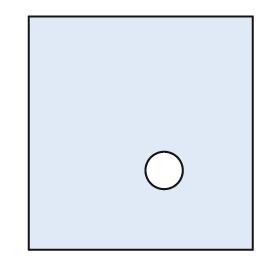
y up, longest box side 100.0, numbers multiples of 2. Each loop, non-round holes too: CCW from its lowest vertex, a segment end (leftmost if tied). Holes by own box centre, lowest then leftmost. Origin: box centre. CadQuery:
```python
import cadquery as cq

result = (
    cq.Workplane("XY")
    .moveTo(-48.0, -50.0)
    .lineTo(48.0, -50.0)
    .lineTo(48.0, 50.0)
    .lineTo(-48.0, 50.0)
    .close()
    .moveTo(10.0, -16.0)
    .circle(8.0)
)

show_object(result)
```